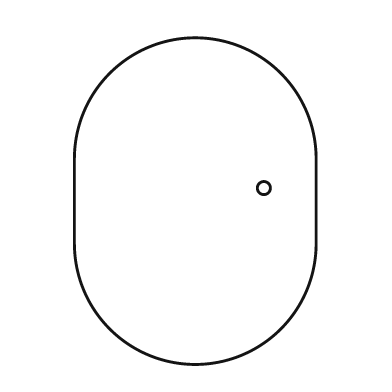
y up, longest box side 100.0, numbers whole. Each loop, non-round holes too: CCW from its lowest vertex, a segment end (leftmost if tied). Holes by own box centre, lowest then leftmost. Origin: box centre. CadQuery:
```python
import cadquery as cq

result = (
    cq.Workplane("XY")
    .moveTo(-37.0, -13.0)
    .threePointArc((0.0, -50.0), (37.0, -13.0))
    .lineTo(37.0, 13.0)
    .threePointArc((0.0, 50.0), (-37.0, 13.0))
    .close()
    .moveTo(21.0, 4.0)
    .circle(2.0)
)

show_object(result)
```